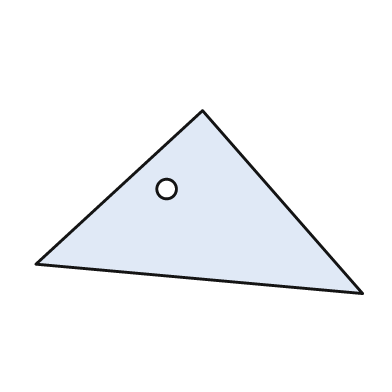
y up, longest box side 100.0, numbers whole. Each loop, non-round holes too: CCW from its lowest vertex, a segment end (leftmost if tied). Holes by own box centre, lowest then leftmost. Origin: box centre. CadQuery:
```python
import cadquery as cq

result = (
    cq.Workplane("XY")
    .moveTo(50.0, -28.0)
    .lineTo(1.0, 28.0)
    .lineTo(-50.0, -19.0)
    .close()
    .moveTo(-10.0, 4.0)
    .circle(3.0)
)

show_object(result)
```